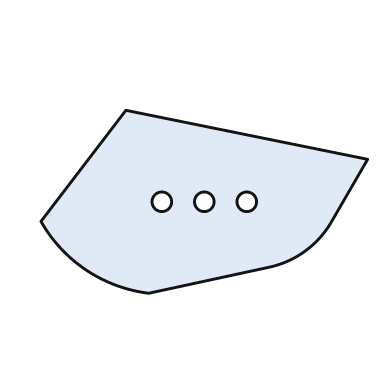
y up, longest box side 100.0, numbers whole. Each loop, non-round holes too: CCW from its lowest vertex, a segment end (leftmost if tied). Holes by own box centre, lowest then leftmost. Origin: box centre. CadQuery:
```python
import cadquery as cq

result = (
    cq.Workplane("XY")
    .moveTo(-17.0, -28.0)
    .lineTo(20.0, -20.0)
    .threePointArc((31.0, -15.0), (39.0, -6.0))
    .lineTo(50.0, 13.0)
    .lineTo(-24.0, 28.0)
    .lineTo(-50.0, -6.0)
    .threePointArc((-36.0, -21.0), (-17.0, -28.0))
    .close()
    .moveTo(-13.0, 0.0)
    .circle(3.0)
    .moveTo(0.0, 0.0)
    .circle(3.0)
    .moveTo(13.0, 0.0)
    .circle(3.0)
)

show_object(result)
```